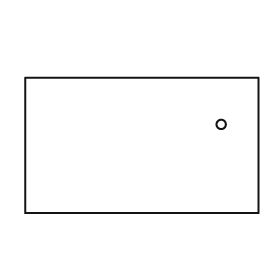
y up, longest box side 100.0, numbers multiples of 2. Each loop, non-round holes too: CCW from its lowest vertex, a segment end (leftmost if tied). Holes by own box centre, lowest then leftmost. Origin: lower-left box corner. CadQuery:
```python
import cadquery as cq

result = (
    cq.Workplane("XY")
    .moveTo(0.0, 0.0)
    .lineTo(100.0, 0.0)
    .lineTo(100.0, 58.0)
    .lineTo(0.0, 58.0)
    .close()
    .moveTo(84.0, 38.0)
    .circle(2.0)
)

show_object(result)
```